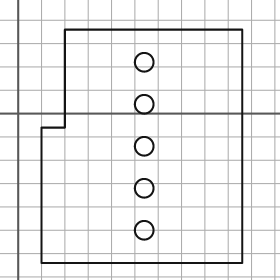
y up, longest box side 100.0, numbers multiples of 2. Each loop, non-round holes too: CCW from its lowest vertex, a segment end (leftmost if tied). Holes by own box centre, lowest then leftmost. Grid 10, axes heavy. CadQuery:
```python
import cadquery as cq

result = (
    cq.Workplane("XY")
    .moveTo(10.0, -64.0)
    .lineTo(96.0, -64.0)
    .lineTo(96.0, 36.0)
    .lineTo(20.0, 36.0)
    .lineTo(20.0, -6.0)
    .lineTo(10.0, -6.0)
    .close()
    .moveTo(54.0, -50.0)
    .circle(4.0)
    .moveTo(54.0, -32.0)
    .circle(4.0)
    .moveTo(54.0, -14.0)
    .circle(4.0)
    .moveTo(54.0, 4.0)
    .circle(4.0)
    .moveTo(54.0, 22.0)
    .circle(4.0)
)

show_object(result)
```